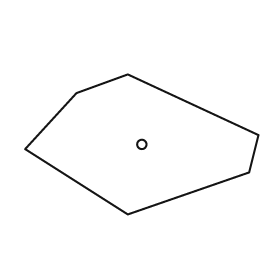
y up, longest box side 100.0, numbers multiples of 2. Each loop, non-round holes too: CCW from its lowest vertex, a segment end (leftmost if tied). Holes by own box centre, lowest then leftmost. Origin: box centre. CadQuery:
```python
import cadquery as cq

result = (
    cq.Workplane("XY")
    .moveTo(-6.0, -30.0)
    .lineTo(46.0, -12.0)
    .lineTo(50.0, 4.0)
    .lineTo(-6.0, 30.0)
    .lineTo(-28.0, 22.0)
    .lineTo(-50.0, -2.0)
    .close()
    .moveTo(0.0, 0.0)
    .circle(2.0)
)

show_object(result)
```